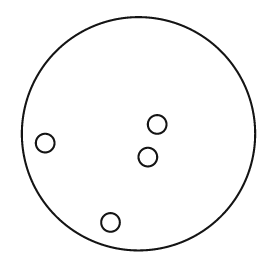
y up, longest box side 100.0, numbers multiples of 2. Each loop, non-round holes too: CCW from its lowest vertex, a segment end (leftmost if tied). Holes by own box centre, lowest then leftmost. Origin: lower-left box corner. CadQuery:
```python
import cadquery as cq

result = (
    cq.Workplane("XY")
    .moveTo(50.0, 50.0)
    .circle(50.0)
    .moveTo(38.0, 12.0)
    .circle(4.0)
    .moveTo(54.0, 40.0)
    .circle(4.0)
    .moveTo(10.0, 46.0)
    .circle(4.0)
    .moveTo(58.0, 54.0)
    .circle(4.0)
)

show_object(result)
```